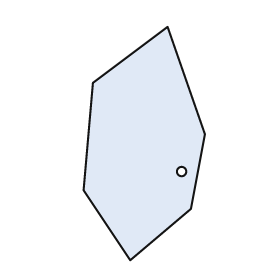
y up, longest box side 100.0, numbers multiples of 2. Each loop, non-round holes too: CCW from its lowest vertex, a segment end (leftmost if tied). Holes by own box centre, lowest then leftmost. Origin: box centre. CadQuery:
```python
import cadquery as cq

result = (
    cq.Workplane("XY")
    .moveTo(-6.0, -50.0)
    .lineTo(20.0, -28.0)
    .lineTo(26.0, 4.0)
    .lineTo(10.0, 50.0)
    .lineTo(-22.0, 26.0)
    .lineTo(-26.0, -20.0)
    .close()
    .moveTo(16.0, -12.0)
    .circle(2.0)
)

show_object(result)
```